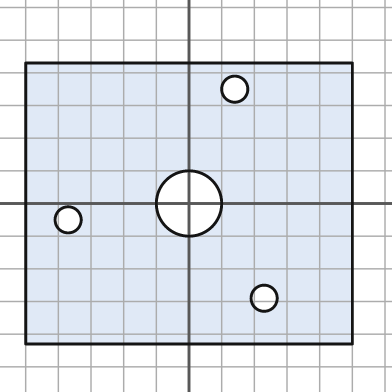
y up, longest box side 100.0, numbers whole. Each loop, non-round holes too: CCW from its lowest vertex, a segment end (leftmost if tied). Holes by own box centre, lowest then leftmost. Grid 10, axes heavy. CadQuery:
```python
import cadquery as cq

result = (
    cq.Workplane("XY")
    .moveTo(-50.0, -43.0)
    .lineTo(50.0, -43.0)
    .lineTo(50.0, 43.0)
    .lineTo(-50.0, 43.0)
    .close()
    .moveTo(23.0, -29.0)
    .circle(4.0)
    .moveTo(-37.0, -5.0)
    .circle(4.0)
    .moveTo(0.0, 0.0)
    .circle(10.0)
    .moveTo(14.0, 35.0)
    .circle(4.0)
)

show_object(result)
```